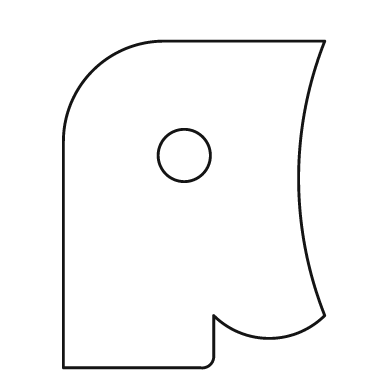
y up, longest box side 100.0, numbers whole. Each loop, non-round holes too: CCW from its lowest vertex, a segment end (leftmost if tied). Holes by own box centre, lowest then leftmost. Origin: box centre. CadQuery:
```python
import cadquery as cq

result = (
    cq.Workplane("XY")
    .moveTo(-40.0, -50.0)
    .lineTo(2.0, -50.0)
    .threePointArc((5.0, -49.0), (6.0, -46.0))
    .lineTo(6.0, -34.0)
    .threePointArc((23.0, -41.0), (40.0, -34.0))
    .threePointArc((32.0, 8.0), (40.0, 50.0))
    .lineTo(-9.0, 50.0)
    .threePointArc((-31.0, 41.0), (-40.0, 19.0))
    .close()
    .moveTo(-3.0, 15.0)
    .circle(8.0)
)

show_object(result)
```